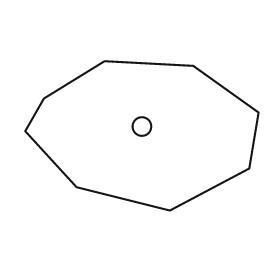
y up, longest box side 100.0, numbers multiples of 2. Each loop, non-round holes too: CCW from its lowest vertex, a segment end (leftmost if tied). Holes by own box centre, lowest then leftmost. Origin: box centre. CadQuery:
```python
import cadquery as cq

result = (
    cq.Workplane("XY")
    .moveTo(12.0, -32.0)
    .lineTo(46.0, -14.0)
    .lineTo(50.0, 10.0)
    .lineTo(22.0, 30.0)
    .lineTo(-16.0, 32.0)
    .lineTo(-42.0, 16.0)
    .lineTo(-50.0, 2.0)
    .lineTo(-28.0, -22.0)
    .close()
    .moveTo(0.0, 4.0)
    .circle(4.0)
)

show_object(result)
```